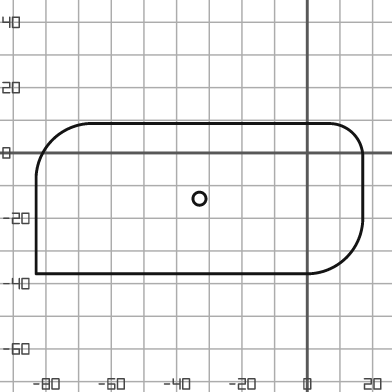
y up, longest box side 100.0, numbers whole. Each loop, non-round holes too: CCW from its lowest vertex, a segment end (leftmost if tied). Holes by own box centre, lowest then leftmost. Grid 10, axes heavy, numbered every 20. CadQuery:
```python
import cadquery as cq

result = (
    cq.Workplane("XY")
    .moveTo(-83.0, -37.0)
    .lineTo(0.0, -37.0)
    .threePointArc((12.0, -32.0), (17.0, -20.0))
    .lineTo(17.0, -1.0)
    .threePointArc((14.0, 6.0), (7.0, 9.0))
    .lineTo(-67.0, 9.0)
    .threePointArc((-78.0, 4.0), (-83.0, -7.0))
    .close()
    .moveTo(-33.0, -14.0)
    .circle(2.0)
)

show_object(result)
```